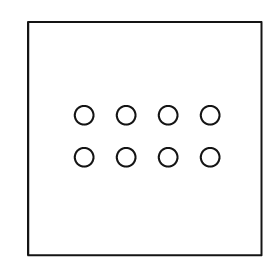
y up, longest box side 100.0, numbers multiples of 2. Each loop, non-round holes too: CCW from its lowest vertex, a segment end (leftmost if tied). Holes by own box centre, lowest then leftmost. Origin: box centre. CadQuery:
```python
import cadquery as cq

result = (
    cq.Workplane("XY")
    .moveTo(-50.0, -50.0)
    .lineTo(50.0, -50.0)
    .lineTo(50.0, 50.0)
    .lineTo(-50.0, 50.0)
    .close()
    .moveTo(-26.0, -8.0)
    .circle(4.0)
    .moveTo(-8.0, -8.0)
    .circle(4.0)
    .moveTo(10.0, -8.0)
    .circle(4.0)
    .moveTo(28.0, -8.0)
    .circle(4.0)
    .moveTo(-26.0, 10.0)
    .circle(4.0)
    .moveTo(-8.0, 10.0)
    .circle(4.0)
    .moveTo(10.0, 10.0)
    .circle(4.0)
    .moveTo(28.0, 10.0)
    .circle(4.0)
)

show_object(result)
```